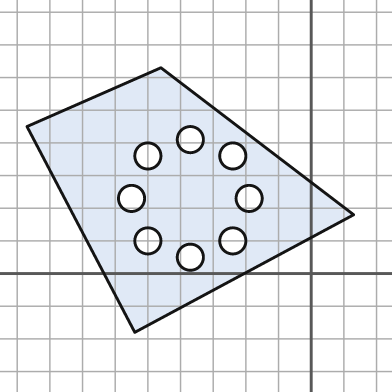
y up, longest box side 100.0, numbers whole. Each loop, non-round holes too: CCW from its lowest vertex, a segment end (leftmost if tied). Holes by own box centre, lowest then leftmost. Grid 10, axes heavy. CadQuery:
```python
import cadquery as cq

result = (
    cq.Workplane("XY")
    .moveTo(-54.0, -18.0)
    .lineTo(13.0, 18.0)
    .lineTo(-46.0, 63.0)
    .lineTo(-87.0, 45.0)
    .close()
    .moveTo(-37.0, 5.0)
    .circle(4.0)
    .moveTo(-50.0, 10.0)
    .circle(4.0)
    .moveTo(-24.0, 10.0)
    .circle(4.0)
    .moveTo(-55.0, 23.0)
    .circle(4.0)
    .moveTo(-19.0, 23.0)
    .circle(4.0)
    .moveTo(-50.0, 36.0)
    .circle(4.0)
    .moveTo(-24.0, 36.0)
    .circle(4.0)
    .moveTo(-37.0, 41.0)
    .circle(4.0)
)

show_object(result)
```